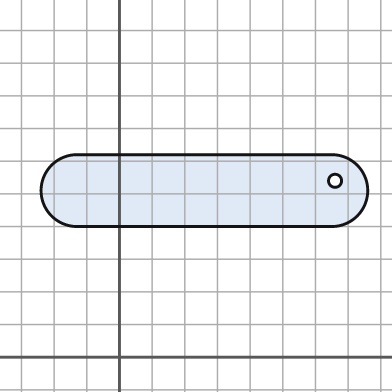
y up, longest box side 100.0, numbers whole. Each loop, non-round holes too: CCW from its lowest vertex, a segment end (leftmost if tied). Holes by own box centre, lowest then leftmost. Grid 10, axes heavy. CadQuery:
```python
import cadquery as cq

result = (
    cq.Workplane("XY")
    .moveTo(-13.0, 40.0)
    .lineTo(65.0, 40.0)
    .threePointArc((76.0, 51.0), (65.0, 62.0))
    .lineTo(-13.0, 62.0)
    .threePointArc((-24.0, 51.0), (-13.0, 40.0))
    .close()
    .moveTo(66.0, 54.0)
    .circle(2.0)
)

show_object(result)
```